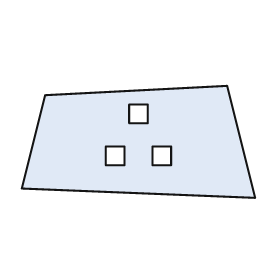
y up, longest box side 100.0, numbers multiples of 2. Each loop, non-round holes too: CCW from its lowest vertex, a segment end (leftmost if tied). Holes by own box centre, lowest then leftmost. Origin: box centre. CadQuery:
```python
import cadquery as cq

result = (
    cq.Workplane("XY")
    .moveTo(50.0, -24.0)
    .lineTo(38.0, 24.0)
    .lineTo(-40.0, 20.0)
    .lineTo(-50.0, -20.0)
    .close()
    .moveTo(-14.0, -10.0)
    .lineTo(-6.0, -10.0)
    .lineTo(-6.0, -2.0)
    .lineTo(-14.0, -2.0)
    .close()
    .moveTo(6.0, -10.0)
    .lineTo(14.0, -10.0)
    .lineTo(14.0, -2.0)
    .lineTo(6.0, -2.0)
    .close()
    .moveTo(-4.0, 8.0)
    .lineTo(4.0, 8.0)
    .lineTo(4.0, 16.0)
    .lineTo(-4.0, 16.0)
    .close()
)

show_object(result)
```